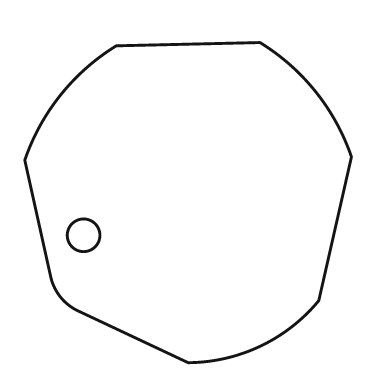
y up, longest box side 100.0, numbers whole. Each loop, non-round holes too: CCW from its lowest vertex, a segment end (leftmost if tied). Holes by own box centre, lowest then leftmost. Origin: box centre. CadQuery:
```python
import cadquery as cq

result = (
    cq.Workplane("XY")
    .moveTo(0.0, -49.0)
    .threePointArc((22.0, -44.0), (40.0, -30.0))
    .lineTo(50.0, 14.0)
    .threePointArc((39.0, 34.0), (22.0, 49.0))
    .lineTo(-22.0, 48.0)
    .threePointArc((-39.0, 33.0), (-50.0, 13.0))
    .lineTo(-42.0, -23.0)
    .threePointArc((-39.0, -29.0), (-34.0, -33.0))
    .close()
    .moveTo(-32.0, -10.0)
    .circle(5.0)
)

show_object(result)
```